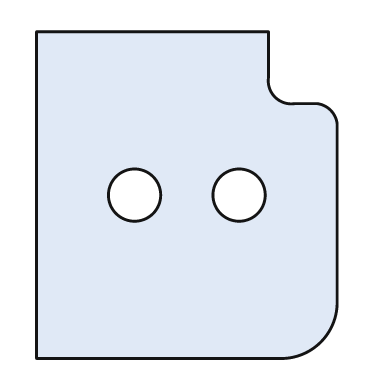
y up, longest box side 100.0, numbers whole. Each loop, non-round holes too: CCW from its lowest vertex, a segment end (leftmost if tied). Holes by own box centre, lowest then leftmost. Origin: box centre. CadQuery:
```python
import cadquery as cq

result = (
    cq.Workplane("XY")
    .moveTo(-46.0, -50.0)
    .lineTo(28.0, -50.0)
    .threePointArc((41.0, -45.0), (46.0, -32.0))
    .lineTo(46.0, 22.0)
    .threePointArc((44.0, 26.0), (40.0, 28.0))
    .lineTo(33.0, 28.0)
    .threePointArc((27.0, 30.0), (25.0, 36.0))
    .lineTo(25.0, 50.0)
    .lineTo(-46.0, 50.0)
    .close()
    .moveTo(-16.0, 0.0)
    .circle(8.0)
    .moveTo(16.0, 0.0)
    .circle(8.0)
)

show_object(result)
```